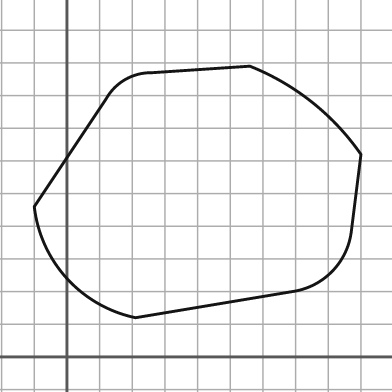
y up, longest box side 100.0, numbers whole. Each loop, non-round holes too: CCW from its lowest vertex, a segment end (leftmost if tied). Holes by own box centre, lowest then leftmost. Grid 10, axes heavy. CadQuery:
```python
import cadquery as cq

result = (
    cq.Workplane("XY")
    .moveTo(21.0, 12.0)
    .lineTo(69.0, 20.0)
    .threePointArc((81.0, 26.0), (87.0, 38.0))
    .lineTo(90.0, 62.0)
    .threePointArc((75.0, 78.0), (56.0, 89.0))
    .lineTo(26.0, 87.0)
    .threePointArc((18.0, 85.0), (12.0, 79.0))
    .lineTo(-10.0, 46.0)
    .threePointArc((0.0, 24.0), (21.0, 12.0))
    .close()
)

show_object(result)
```